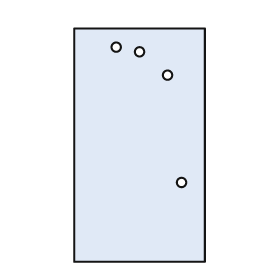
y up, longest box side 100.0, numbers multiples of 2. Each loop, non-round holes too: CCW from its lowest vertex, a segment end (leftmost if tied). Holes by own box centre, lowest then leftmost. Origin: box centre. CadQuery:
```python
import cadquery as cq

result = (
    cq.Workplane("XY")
    .moveTo(-28.0, -50.0)
    .lineTo(28.0, -50.0)
    .lineTo(28.0, 50.0)
    .lineTo(-28.0, 50.0)
    .close()
    .moveTo(18.0, -16.0)
    .circle(2.0)
    .moveTo(12.0, 30.0)
    .circle(2.0)
    .moveTo(0.0, 40.0)
    .circle(2.0)
    .moveTo(-10.0, 42.0)
    .circle(2.0)
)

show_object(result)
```